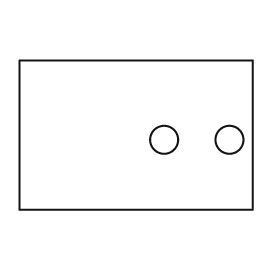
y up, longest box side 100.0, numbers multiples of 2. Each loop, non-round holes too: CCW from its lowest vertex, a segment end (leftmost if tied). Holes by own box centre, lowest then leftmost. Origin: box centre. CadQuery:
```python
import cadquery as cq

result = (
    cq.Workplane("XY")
    .moveTo(-50.0, -32.0)
    .lineTo(50.0, -32.0)
    .lineTo(50.0, 32.0)
    .lineTo(-50.0, 32.0)
    .close()
    .moveTo(12.0, -2.0)
    .circle(6.0)
    .moveTo(40.0, -2.0)
    .circle(6.0)
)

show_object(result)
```